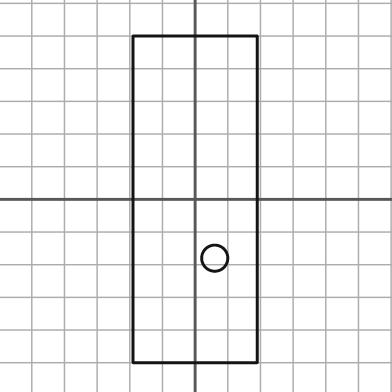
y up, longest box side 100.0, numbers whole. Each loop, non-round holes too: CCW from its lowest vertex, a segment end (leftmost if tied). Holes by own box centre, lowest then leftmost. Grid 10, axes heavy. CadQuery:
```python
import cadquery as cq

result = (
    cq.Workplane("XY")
    .moveTo(-19.0, -50.0)
    .lineTo(19.0, -50.0)
    .lineTo(19.0, 50.0)
    .lineTo(-19.0, 50.0)
    .close()
    .moveTo(6.0, -18.0)
    .circle(4.0)
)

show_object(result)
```